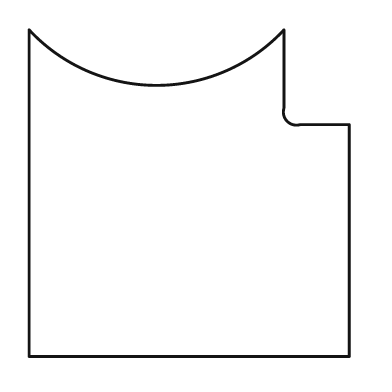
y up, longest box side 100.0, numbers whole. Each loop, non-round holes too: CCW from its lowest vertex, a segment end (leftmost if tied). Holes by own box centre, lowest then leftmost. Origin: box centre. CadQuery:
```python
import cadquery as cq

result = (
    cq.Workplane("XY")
    .moveTo(-49.0, -50.0)
    .lineTo(49.0, -50.0)
    .lineTo(49.0, 21.0)
    .lineTo(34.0, 21.0)
    .threePointArc((30.0, 22.0), (29.0, 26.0))
    .lineTo(29.0, 50.0)
    .threePointArc((-10.0, 33.0), (-49.0, 50.0))
    .close()
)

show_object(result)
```